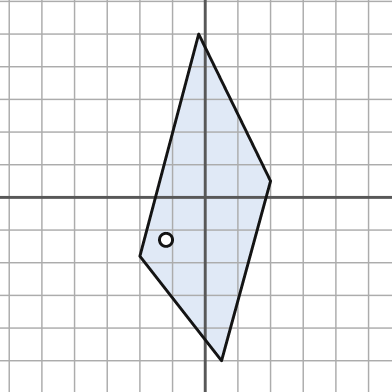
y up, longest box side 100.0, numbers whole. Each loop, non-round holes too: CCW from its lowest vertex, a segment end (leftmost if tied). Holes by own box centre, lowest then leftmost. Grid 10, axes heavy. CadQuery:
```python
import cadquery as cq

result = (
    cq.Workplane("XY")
    .moveTo(5.0, -50.0)
    .lineTo(20.0, 5.0)
    .lineTo(-2.0, 50.0)
    .lineTo(-20.0, -18.0)
    .close()
    .moveTo(-12.0, -13.0)
    .circle(2.0)
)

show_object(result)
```